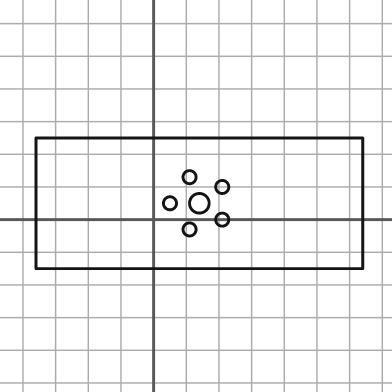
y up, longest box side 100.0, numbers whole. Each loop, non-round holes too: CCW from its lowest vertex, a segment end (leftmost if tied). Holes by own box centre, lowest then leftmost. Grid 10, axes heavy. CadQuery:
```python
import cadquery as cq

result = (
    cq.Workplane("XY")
    .moveTo(-36.0, -15.0)
    .lineTo(64.0, -15.0)
    .lineTo(64.0, 25.0)
    .lineTo(-36.0, 25.0)
    .close()
    .moveTo(11.0, -3.0)
    .circle(2.0)
    .moveTo(21.0, 0.0)
    .circle(2.0)
    .moveTo(5.0, 5.0)
    .circle(2.0)
    .moveTo(14.0, 5.0)
    .circle(3.0)
    .moveTo(21.0, 10.0)
    .circle(2.0)
    .moveTo(11.0, 13.0)
    .circle(2.0)
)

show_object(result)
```